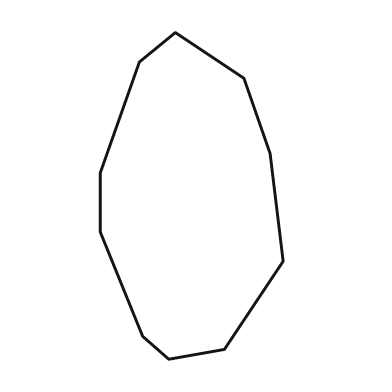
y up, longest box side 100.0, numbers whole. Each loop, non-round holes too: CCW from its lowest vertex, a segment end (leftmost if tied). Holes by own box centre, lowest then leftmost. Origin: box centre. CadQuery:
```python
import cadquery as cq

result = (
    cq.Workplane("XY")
    .moveTo(-7.0, -50.0)
    .lineTo(10.0, -47.0)
    .lineTo(28.0, -20.0)
    .lineTo(24.0, 13.0)
    .lineTo(16.0, 36.0)
    .lineTo(-5.0, 50.0)
    .lineTo(-16.0, 41.0)
    .lineTo(-28.0, 7.0)
    .lineTo(-28.0, -11.0)
    .lineTo(-15.0, -43.0)
    .close()
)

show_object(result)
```